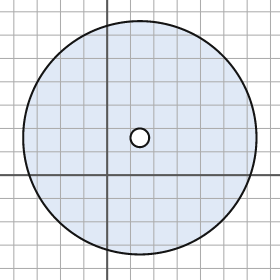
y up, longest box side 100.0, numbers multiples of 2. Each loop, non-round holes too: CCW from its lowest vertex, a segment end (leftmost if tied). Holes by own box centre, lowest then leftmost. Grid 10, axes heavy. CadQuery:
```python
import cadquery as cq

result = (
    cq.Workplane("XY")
    .moveTo(14.0, 16.0)
    .circle(50.0)
    .moveTo(14.0, 16.0)
    .circle(4.0)
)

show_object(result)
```